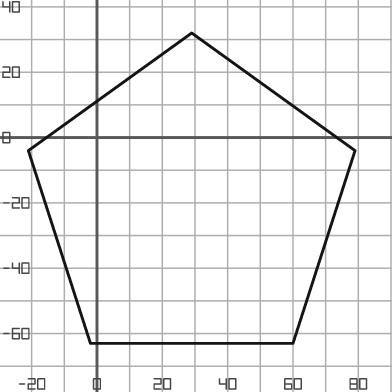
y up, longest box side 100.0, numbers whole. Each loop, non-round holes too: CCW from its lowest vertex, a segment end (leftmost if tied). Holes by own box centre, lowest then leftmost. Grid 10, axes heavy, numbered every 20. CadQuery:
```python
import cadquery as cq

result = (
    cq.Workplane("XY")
    .moveTo(-2.0, -63.0)
    .lineTo(60.0, -63.0)
    .lineTo(79.0, -4.0)
    .lineTo(29.0, 32.0)
    .lineTo(-21.0, -4.0)
    .close()
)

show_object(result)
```